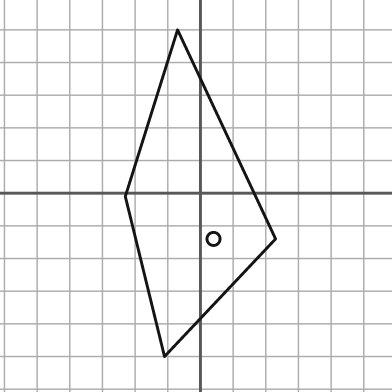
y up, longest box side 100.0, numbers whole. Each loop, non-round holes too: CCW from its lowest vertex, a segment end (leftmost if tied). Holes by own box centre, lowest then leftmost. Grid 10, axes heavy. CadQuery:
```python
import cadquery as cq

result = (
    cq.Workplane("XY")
    .moveTo(-11.0, -50.0)
    .lineTo(23.0, -14.0)
    .lineTo(-7.0, 50.0)
    .lineTo(-23.0, -1.0)
    .close()
    .moveTo(4.0, -14.0)
    .circle(2.0)
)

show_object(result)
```